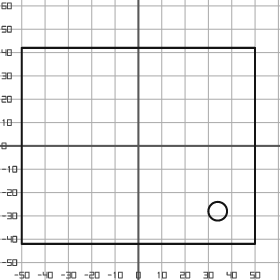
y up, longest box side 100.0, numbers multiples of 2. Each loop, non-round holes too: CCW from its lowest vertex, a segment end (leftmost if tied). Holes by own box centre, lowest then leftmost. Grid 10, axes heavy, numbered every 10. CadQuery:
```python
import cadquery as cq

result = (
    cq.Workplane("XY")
    .moveTo(-50.0, -42.0)
    .lineTo(50.0, -42.0)
    .lineTo(50.0, 42.0)
    .lineTo(-50.0, 42.0)
    .close()
    .moveTo(34.0, -28.0)
    .circle(4.0)
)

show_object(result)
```